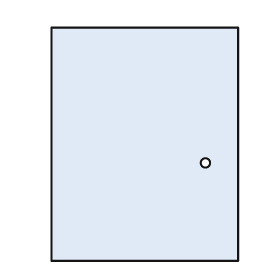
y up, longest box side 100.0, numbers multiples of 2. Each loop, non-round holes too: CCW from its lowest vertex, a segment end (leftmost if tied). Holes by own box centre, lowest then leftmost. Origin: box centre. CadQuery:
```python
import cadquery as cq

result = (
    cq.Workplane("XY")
    .moveTo(-40.0, -50.0)
    .lineTo(40.0, -50.0)
    .lineTo(40.0, 50.0)
    .lineTo(-40.0, 50.0)
    .close()
    .moveTo(26.0, -8.0)
    .circle(2.0)
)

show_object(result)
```